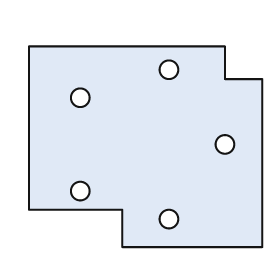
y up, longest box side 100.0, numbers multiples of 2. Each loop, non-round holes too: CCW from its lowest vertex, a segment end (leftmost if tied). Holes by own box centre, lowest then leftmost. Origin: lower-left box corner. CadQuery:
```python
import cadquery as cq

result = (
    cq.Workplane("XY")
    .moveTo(40.0, 0.0)
    .lineTo(100.0, 0.0)
    .lineTo(100.0, 72.0)
    .lineTo(84.0, 72.0)
    .lineTo(84.0, 86.0)
    .lineTo(0.0, 86.0)
    .lineTo(0.0, 16.0)
    .lineTo(40.0, 16.0)
    .close()
    .moveTo(60.0, 12.0)
    .circle(4.0)
    .moveTo(22.0, 24.0)
    .circle(4.0)
    .moveTo(84.0, 44.0)
    .circle(4.0)
    .moveTo(22.0, 64.0)
    .circle(4.0)
    .moveTo(60.0, 76.0)
    .circle(4.0)
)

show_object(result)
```